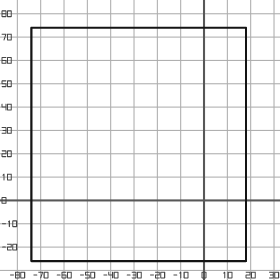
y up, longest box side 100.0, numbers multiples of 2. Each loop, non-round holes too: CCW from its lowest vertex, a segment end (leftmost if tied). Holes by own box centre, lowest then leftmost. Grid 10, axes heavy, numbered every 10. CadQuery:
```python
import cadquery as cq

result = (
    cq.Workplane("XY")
    .moveTo(-74.0, -26.0)
    .lineTo(18.0, -26.0)
    .lineTo(18.0, 74.0)
    .lineTo(-74.0, 74.0)
    .close()
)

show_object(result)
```